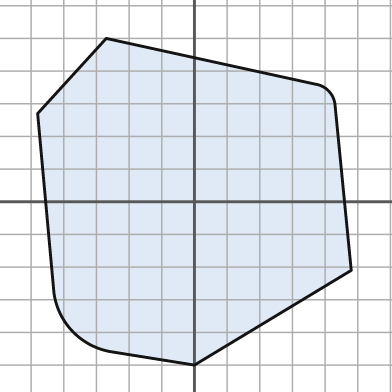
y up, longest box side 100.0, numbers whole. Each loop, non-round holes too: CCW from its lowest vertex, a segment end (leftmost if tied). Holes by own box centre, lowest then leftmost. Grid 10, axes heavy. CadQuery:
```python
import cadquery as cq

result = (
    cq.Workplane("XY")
    .moveTo(0.0, -50.0)
    .lineTo(48.0, -21.0)
    .lineTo(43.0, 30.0)
    .threePointArc((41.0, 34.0), (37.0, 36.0))
    .lineTo(-27.0, 50.0)
    .lineTo(-48.0, 27.0)
    .lineTo(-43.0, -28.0)
    .threePointArc((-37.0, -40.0), (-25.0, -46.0))
    .close()
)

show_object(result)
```